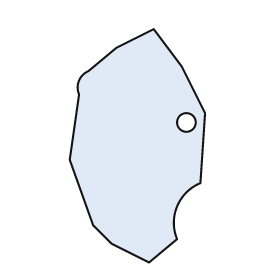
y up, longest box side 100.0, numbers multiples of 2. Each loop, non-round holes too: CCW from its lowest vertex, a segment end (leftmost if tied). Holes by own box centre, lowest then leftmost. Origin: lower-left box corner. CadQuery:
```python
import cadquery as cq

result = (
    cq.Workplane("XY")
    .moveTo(34.0, 0.0)
    .lineTo(46.0, 10.0)
    .threePointArc((46.0, 24.0), (56.0, 34.0))
    .lineTo(58.0, 64.0)
    .lineTo(48.0, 84.0)
    .lineTo(36.0, 100.0)
    .lineTo(20.0, 92.0)
    .lineTo(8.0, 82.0)
    .threePointArc((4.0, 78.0), (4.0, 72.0))
    .lineTo(0.0, 44.0)
    .lineTo(10.0, 16.0)
    .lineTo(18.0, 8.0)
    .close()
    .moveTo(50.0, 60.0)
    .circle(4.0)
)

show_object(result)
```